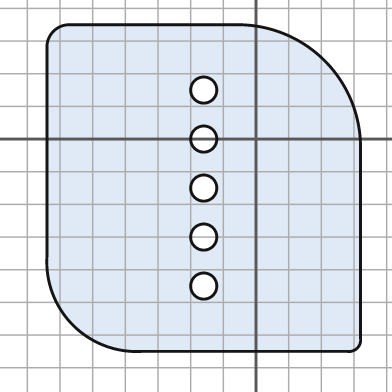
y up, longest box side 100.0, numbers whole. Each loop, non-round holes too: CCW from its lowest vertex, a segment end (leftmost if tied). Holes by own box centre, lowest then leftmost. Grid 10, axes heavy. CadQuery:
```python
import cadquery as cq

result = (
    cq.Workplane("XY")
    .moveTo(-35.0, -65.0)
    .lineTo(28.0, -65.0)
    .threePointArc((31.0, -64.0), (32.0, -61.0))
    .lineTo(32.0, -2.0)
    .threePointArc((21.0, 24.0), (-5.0, 35.0))
    .lineTo(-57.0, 35.0)
    .threePointArc((-62.0, 33.0), (-64.0, 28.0))
    .lineTo(-64.0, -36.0)
    .threePointArc((-56.0, -57.0), (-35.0, -65.0))
    .close()
    .moveTo(-16.0, -45.0)
    .circle(4.0)
    .moveTo(-16.0, -30.0)
    .circle(4.0)
    .moveTo(-16.0, -15.0)
    .circle(4.0)
    .moveTo(-16.0, 0.0)
    .circle(4.0)
    .moveTo(-16.0, 15.0)
    .circle(4.0)
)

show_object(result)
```